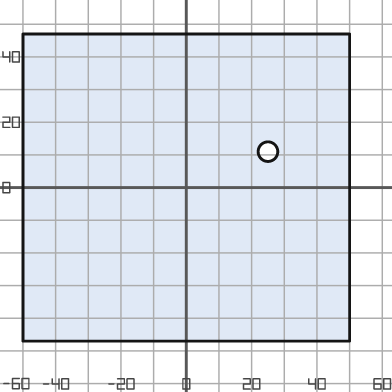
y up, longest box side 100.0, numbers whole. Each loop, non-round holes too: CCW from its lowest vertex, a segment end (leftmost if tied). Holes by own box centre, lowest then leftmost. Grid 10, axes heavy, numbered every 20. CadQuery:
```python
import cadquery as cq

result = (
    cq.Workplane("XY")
    .moveTo(-50.0, -47.0)
    .lineTo(50.0, -47.0)
    .lineTo(50.0, 47.0)
    .lineTo(-50.0, 47.0)
    .close()
    .moveTo(25.0, 11.0)
    .circle(3.0)
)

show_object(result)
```